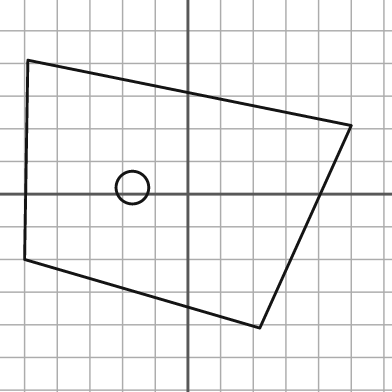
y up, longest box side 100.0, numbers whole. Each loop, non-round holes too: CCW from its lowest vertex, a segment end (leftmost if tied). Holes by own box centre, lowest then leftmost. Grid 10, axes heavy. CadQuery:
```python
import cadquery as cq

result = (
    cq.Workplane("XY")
    .moveTo(22.0, -41.0)
    .lineTo(50.0, 21.0)
    .lineTo(-49.0, 41.0)
    .lineTo(-50.0, -20.0)
    .close()
    .moveTo(-17.0, 2.0)
    .circle(5.0)
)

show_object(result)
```